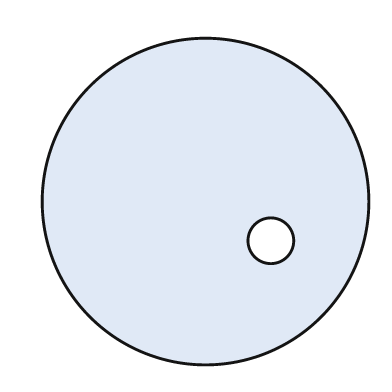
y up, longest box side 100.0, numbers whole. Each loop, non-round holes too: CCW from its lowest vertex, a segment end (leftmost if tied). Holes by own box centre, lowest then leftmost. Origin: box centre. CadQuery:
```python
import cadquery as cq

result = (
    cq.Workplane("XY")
    .moveTo(0.0, 0.0)
    .circle(50.0)
    .moveTo(20.0, -12.0)
    .circle(7.0)
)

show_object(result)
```